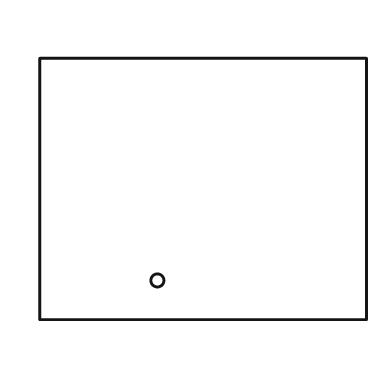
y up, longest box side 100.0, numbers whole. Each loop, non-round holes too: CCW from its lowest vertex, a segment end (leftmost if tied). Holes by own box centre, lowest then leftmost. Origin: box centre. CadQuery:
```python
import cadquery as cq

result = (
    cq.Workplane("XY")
    .moveTo(-50.0, -40.0)
    .lineTo(50.0, -40.0)
    .lineTo(50.0, 40.0)
    .lineTo(-50.0, 40.0)
    .close()
    .moveTo(-14.0, -28.0)
    .circle(2.0)
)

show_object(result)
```